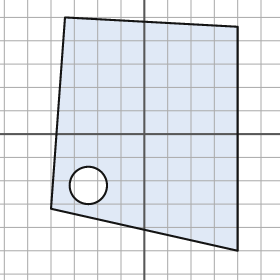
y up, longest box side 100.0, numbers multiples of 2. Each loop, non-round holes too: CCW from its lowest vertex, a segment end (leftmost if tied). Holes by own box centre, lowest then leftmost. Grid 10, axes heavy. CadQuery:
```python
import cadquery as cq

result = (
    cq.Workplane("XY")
    .moveTo(40.0, -50.0)
    .lineTo(40.0, 46.0)
    .lineTo(-34.0, 50.0)
    .lineTo(-40.0, -32.0)
    .close()
    .moveTo(-24.0, -22.0)
    .circle(8.0)
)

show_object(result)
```